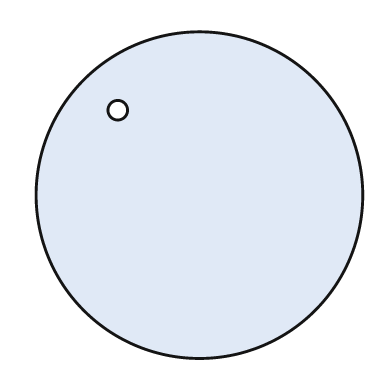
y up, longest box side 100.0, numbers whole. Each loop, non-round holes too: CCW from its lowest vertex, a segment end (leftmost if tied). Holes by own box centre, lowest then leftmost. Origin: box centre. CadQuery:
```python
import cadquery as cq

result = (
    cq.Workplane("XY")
    .moveTo(0.0, 0.0)
    .circle(50.0)
    .moveTo(-25.0, 26.0)
    .circle(3.0)
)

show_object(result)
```